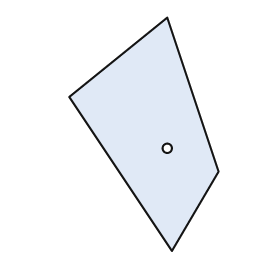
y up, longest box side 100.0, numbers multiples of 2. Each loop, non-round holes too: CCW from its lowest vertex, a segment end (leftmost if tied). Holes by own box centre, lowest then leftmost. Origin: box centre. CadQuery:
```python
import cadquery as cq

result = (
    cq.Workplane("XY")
    .moveTo(12.0, -50.0)
    .lineTo(32.0, -16.0)
    .lineTo(10.0, 50.0)
    .lineTo(-32.0, 16.0)
    .close()
    .moveTo(10.0, -6.0)
    .circle(2.0)
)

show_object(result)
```